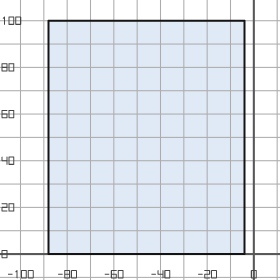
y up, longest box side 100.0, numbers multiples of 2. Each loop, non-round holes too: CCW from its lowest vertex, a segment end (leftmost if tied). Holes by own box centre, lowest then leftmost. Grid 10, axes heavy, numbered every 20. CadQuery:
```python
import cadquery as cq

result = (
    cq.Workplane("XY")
    .moveTo(-88.0, 0.0)
    .lineTo(-4.0, 0.0)
    .lineTo(-4.0, 100.0)
    .lineTo(-88.0, 100.0)
    .close()
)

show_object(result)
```